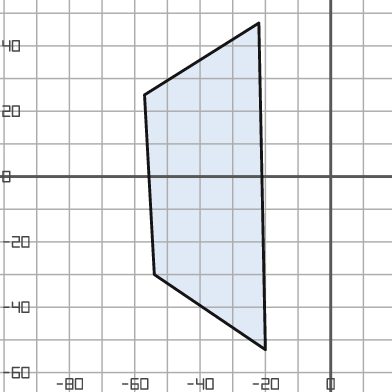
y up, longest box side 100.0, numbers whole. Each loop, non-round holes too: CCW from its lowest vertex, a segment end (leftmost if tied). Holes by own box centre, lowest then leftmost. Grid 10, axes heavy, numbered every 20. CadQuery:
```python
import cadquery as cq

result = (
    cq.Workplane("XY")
    .moveTo(-20.0, -53.0)
    .lineTo(-22.0, 47.0)
    .lineTo(-57.0, 25.0)
    .lineTo(-54.0, -30.0)
    .close()
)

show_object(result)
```